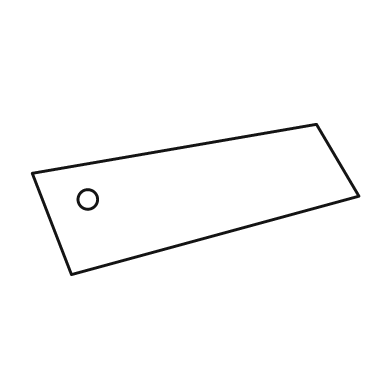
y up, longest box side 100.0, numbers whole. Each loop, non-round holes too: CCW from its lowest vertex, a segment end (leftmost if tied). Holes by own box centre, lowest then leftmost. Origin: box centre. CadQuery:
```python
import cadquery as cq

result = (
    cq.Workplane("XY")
    .moveTo(-38.0, -23.0)
    .lineTo(50.0, 1.0)
    .lineTo(37.0, 23.0)
    .lineTo(-50.0, 8.0)
    .close()
    .moveTo(-33.0, 0.0)
    .circle(3.0)
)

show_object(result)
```